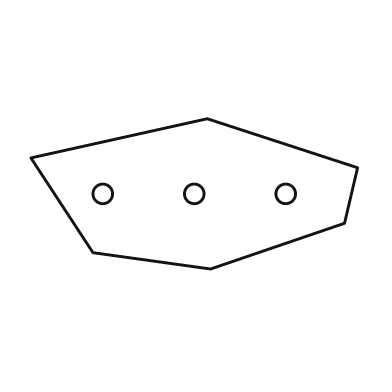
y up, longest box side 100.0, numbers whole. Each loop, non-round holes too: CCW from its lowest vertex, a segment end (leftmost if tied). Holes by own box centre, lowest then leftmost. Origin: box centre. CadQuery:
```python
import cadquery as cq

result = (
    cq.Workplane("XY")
    .moveTo(5.0, -23.0)
    .lineTo(46.0, -9.0)
    .lineTo(50.0, 8.0)
    .lineTo(4.0, 23.0)
    .lineTo(-50.0, 11.0)
    .lineTo(-31.0, -18.0)
    .close()
    .moveTo(-28.0, 0.0)
    .circle(3.0)
    .moveTo(0.0, 0.0)
    .circle(3.0)
    .moveTo(28.0, 0.0)
    .circle(3.0)
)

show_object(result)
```